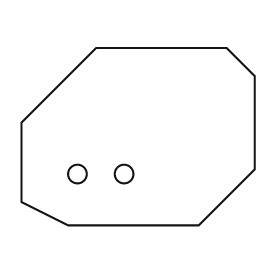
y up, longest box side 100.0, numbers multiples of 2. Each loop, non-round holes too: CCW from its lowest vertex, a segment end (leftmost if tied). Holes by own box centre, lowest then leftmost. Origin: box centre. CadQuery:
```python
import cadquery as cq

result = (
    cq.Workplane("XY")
    .moveTo(-30.0, -38.0)
    .lineTo(26.0, -38.0)
    .lineTo(50.0, -14.0)
    .lineTo(50.0, 26.0)
    .lineTo(38.0, 38.0)
    .lineTo(-18.0, 38.0)
    .lineTo(-50.0, 6.0)
    .lineTo(-50.0, -28.0)
    .close()
    .moveTo(-26.0, -16.0)
    .circle(4.0)
    .moveTo(-6.0, -16.0)
    .circle(4.0)
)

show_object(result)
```